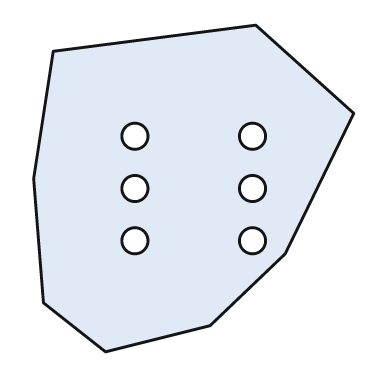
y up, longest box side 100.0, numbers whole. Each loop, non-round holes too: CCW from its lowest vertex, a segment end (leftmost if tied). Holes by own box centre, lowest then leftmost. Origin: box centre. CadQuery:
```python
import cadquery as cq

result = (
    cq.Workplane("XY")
    .moveTo(-27.0, -50.0)
    .lineTo(5.0, -42.0)
    .lineTo(28.0, -20.0)
    .lineTo(49.0, 23.0)
    .lineTo(19.0, 50.0)
    .lineTo(-43.0, 42.0)
    .lineTo(-49.0, 3.0)
    .lineTo(-46.0, -35.0)
    .close()
    .moveTo(-18.0, -16.0)
    .circle(4.0)
    .moveTo(18.0, -16.0)
    .circle(4.0)
    .moveTo(-18.0, 0.0)
    .circle(4.0)
    .moveTo(18.0, 0.0)
    .circle(4.0)
    .moveTo(-18.0, 16.0)
    .circle(4.0)
    .moveTo(18.0, 16.0)
    .circle(4.0)
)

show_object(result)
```